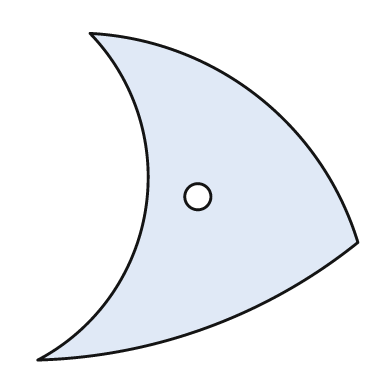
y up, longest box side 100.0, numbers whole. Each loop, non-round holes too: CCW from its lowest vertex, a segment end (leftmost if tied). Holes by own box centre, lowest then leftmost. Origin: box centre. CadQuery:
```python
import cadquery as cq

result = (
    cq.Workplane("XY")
    .moveTo(-49.0, -50.0)
    .threePointArc((3.0, -40.0), (49.0, -14.0))
    .threePointArc((18.0, 31.0), (-33.0, 50.0))
    .threePointArc((-16.0, -4.0), (-49.0, -50.0))
    .close()
    .moveTo(0.0, 0.0)
    .circle(4.0)
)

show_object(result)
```